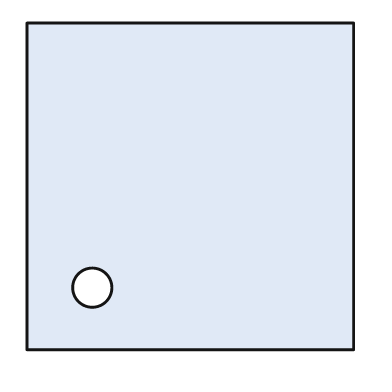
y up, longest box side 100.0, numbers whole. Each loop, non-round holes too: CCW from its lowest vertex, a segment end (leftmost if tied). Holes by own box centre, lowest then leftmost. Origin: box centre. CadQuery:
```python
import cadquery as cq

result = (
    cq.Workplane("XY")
    .moveTo(-50.0, -50.0)
    .lineTo(50.0, -50.0)
    .lineTo(50.0, 50.0)
    .lineTo(-50.0, 50.0)
    .close()
    .moveTo(-30.0, -31.0)
    .circle(6.0)
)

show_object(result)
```